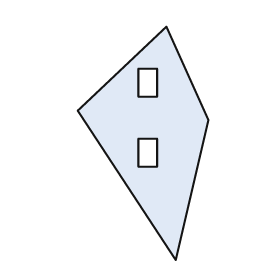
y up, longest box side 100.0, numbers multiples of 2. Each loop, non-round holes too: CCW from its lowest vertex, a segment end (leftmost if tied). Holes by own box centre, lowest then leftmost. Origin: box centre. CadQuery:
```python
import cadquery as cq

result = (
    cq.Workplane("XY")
    .moveTo(14.0, -50.0)
    .lineTo(28.0, 10.0)
    .lineTo(10.0, 50.0)
    .lineTo(-28.0, 14.0)
    .close()
    .moveTo(-2.0, -10.0)
    .lineTo(6.0, -10.0)
    .lineTo(6.0, 2.0)
    .lineTo(-2.0, 2.0)
    .close()
    .moveTo(-2.0, 20.0)
    .lineTo(6.0, 20.0)
    .lineTo(6.0, 32.0)
    .lineTo(-2.0, 32.0)
    .close()
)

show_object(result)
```